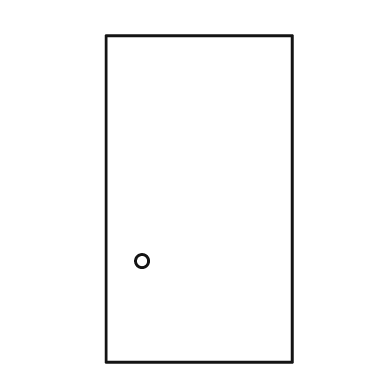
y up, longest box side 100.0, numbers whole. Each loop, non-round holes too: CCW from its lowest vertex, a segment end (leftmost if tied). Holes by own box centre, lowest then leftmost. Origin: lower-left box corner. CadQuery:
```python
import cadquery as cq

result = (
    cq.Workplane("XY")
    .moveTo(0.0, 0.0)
    .lineTo(57.0, 0.0)
    .lineTo(57.0, 100.0)
    .lineTo(0.0, 100.0)
    .close()
    .moveTo(11.0, 31.0)
    .circle(2.0)
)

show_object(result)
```